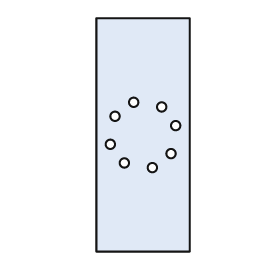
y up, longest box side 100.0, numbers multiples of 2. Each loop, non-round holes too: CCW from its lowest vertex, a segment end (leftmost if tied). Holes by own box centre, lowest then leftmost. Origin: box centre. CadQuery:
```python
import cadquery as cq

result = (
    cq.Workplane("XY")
    .moveTo(-20.0, -50.0)
    .lineTo(20.0, -50.0)
    .lineTo(20.0, 50.0)
    .lineTo(-20.0, 50.0)
    .close()
    .moveTo(4.0, -14.0)
    .circle(2.0)
    .moveTo(-8.0, -12.0)
    .circle(2.0)
    .moveTo(12.0, -8.0)
    .circle(2.0)
    .moveTo(-14.0, -4.0)
    .circle(2.0)
    .moveTo(14.0, 4.0)
    .circle(2.0)
    .moveTo(-12.0, 8.0)
    .circle(2.0)
    .moveTo(8.0, 12.0)
    .circle(2.0)
    .moveTo(-4.0, 14.0)
    .circle(2.0)
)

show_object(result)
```